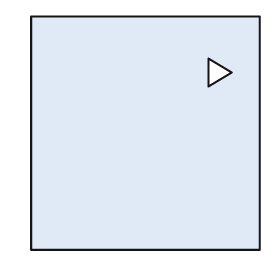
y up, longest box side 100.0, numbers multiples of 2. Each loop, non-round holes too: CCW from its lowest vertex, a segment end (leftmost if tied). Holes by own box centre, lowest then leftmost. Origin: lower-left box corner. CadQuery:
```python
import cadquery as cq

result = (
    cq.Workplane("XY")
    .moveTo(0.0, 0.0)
    .lineTo(98.0, 0.0)
    .lineTo(98.0, 100.0)
    .lineTo(0.0, 100.0)
    .close()
    .moveTo(76.0, 70.0)
    .lineTo(86.0, 76.0)
    .lineTo(76.0, 82.0)
    .close()
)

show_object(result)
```